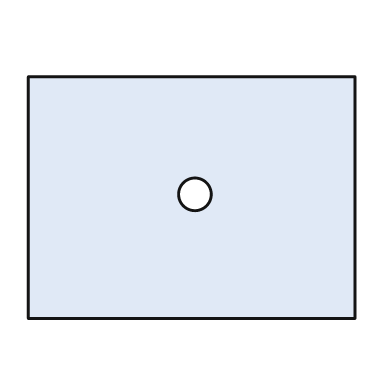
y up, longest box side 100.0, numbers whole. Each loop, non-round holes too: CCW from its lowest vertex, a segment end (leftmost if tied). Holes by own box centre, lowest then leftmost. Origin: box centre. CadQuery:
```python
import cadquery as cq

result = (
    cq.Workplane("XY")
    .moveTo(-50.0, -37.0)
    .lineTo(50.0, -37.0)
    .lineTo(50.0, 37.0)
    .lineTo(-50.0, 37.0)
    .close()
    .moveTo(1.0, 1.0)
    .circle(5.0)
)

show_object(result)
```